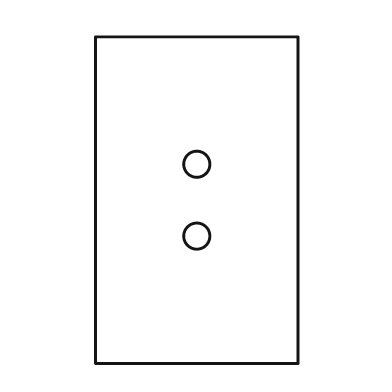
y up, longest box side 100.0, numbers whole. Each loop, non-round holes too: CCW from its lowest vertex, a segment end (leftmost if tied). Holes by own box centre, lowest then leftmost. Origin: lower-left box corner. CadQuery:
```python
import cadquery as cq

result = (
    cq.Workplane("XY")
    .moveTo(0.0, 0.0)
    .lineTo(62.0, 0.0)
    .lineTo(62.0, 100.0)
    .lineTo(0.0, 100.0)
    .close()
    .moveTo(31.0, 39.0)
    .circle(4.0)
    .moveTo(31.0, 61.0)
    .circle(4.0)
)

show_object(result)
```